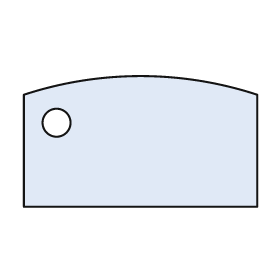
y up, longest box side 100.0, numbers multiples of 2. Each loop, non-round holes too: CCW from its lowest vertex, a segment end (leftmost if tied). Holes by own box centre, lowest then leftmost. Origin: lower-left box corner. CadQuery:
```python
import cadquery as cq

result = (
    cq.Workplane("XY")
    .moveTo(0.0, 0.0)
    .lineTo(100.0, 0.0)
    .lineTo(100.0, 48.0)
    .threePointArc((50.0, 56.0), (0.0, 48.0))
    .close()
    .moveTo(14.0, 36.0)
    .circle(6.0)
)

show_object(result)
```